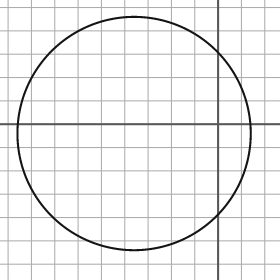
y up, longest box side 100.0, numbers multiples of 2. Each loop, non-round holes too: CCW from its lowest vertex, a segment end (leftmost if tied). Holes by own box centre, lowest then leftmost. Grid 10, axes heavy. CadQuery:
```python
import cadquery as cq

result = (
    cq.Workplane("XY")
    .moveTo(-36.0, -4.0)
    .circle(50.0)
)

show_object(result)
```